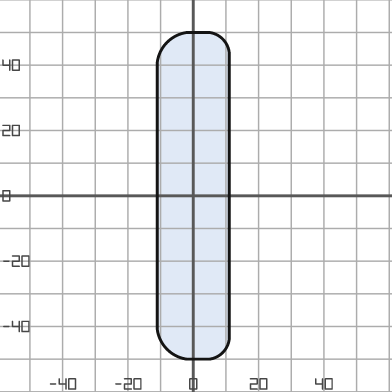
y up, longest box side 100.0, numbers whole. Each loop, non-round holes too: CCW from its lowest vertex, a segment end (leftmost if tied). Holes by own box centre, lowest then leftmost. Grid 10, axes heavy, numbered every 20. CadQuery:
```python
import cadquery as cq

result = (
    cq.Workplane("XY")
    .moveTo(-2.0, -50.0)
    .lineTo(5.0, -50.0)
    .threePointArc((9.0, -48.0), (11.0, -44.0))
    .lineTo(11.0, 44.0)
    .threePointArc((9.0, 48.0), (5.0, 50.0))
    .lineTo(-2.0, 50.0)
    .threePointArc((-8.0, 47.0), (-11.0, 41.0))
    .lineTo(-11.0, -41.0)
    .threePointArc((-8.0, -47.0), (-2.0, -50.0))
    .close()
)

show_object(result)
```